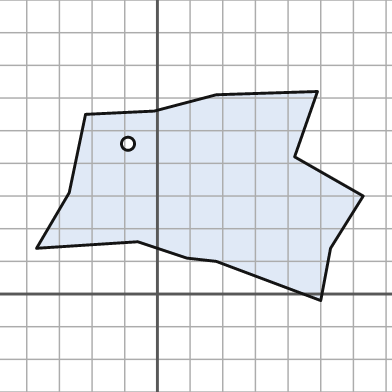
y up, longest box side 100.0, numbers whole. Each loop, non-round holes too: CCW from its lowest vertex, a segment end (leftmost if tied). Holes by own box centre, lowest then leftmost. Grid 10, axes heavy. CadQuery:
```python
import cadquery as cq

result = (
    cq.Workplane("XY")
    .moveTo(50.0, -2.0)
    .lineTo(53.0, 14.0)
    .lineTo(63.0, 30.0)
    .lineTo(42.0, 42.0)
    .lineTo(49.0, 62.0)
    .lineTo(18.0, 61.0)
    .lineTo(-1.0, 56.0)
    .lineTo(-22.0, 55.0)
    .lineTo(-27.0, 31.0)
    .lineTo(-37.0, 14.0)
    .lineTo(-6.0, 16.0)
    .lineTo(9.0, 11.0)
    .lineTo(18.0, 10.0)
    .close()
    .moveTo(-9.0, 46.0)
    .circle(2.0)
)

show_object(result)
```